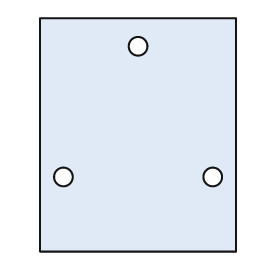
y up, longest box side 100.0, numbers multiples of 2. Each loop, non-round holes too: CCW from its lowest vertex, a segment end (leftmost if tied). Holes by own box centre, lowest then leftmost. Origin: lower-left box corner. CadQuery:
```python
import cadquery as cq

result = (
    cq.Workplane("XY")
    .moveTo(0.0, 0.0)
    .lineTo(84.0, 0.0)
    .lineTo(84.0, 100.0)
    .lineTo(0.0, 100.0)
    .close()
    .moveTo(10.0, 32.0)
    .circle(4.0)
    .moveTo(74.0, 32.0)
    .circle(4.0)
    .moveTo(42.0, 88.0)
    .circle(4.0)
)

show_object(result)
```